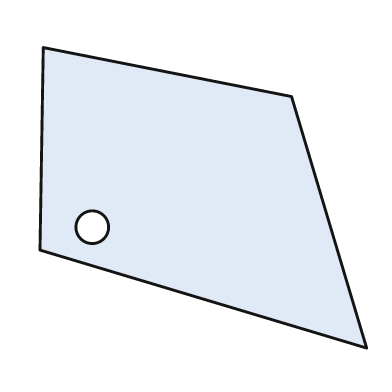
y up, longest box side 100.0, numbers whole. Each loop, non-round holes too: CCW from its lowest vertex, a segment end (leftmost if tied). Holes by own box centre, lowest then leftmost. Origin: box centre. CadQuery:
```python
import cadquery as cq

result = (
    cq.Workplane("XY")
    .moveTo(50.0, -46.0)
    .lineTo(27.0, 31.0)
    .lineTo(-49.0, 46.0)
    .lineTo(-50.0, -16.0)
    .close()
    .moveTo(-34.0, -9.0)
    .circle(5.0)
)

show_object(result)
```